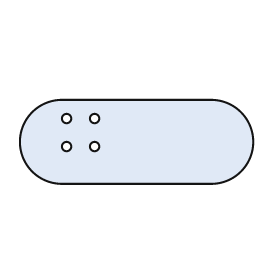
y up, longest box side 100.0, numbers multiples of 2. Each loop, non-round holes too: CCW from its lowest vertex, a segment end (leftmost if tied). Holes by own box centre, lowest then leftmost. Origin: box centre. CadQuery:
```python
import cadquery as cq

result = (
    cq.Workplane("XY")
    .moveTo(-32.0, -18.0)
    .lineTo(32.0, -18.0)
    .threePointArc((50.0, 0.0), (32.0, 18.0))
    .lineTo(-32.0, 18.0)
    .threePointArc((-50.0, 0.0), (-32.0, -18.0))
    .close()
    .moveTo(-30.0, -2.0)
    .circle(2.0)
    .moveTo(-18.0, -2.0)
    .circle(2.0)
    .moveTo(-30.0, 10.0)
    .circle(2.0)
    .moveTo(-18.0, 10.0)
    .circle(2.0)
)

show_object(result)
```